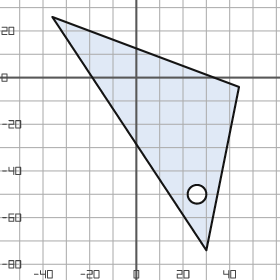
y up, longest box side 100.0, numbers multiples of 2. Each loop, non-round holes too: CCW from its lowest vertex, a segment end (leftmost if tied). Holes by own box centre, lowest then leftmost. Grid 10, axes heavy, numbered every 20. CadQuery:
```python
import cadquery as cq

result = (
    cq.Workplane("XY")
    .moveTo(30.0, -74.0)
    .lineTo(44.0, -4.0)
    .lineTo(-36.0, 26.0)
    .close()
    .moveTo(26.0, -50.0)
    .circle(4.0)
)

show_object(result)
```